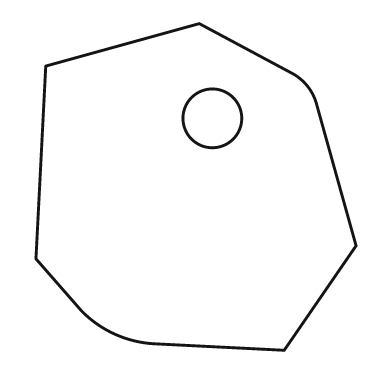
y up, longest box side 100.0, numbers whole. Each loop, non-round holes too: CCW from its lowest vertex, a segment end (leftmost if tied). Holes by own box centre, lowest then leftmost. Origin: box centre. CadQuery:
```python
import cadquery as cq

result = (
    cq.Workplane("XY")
    .moveTo(27.0, -50.0)
    .lineTo(49.0, -18.0)
    .lineTo(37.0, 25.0)
    .threePointArc((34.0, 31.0), (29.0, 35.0))
    .lineTo(1.0, 50.0)
    .lineTo(-46.0, 37.0)
    .lineTo(-49.0, -22.0)
    .lineTo(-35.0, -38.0)
    .threePointArc((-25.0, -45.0), (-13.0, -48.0))
    .close()
    .moveTo(5.0, 21.0)
    .circle(9.0)
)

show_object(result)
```